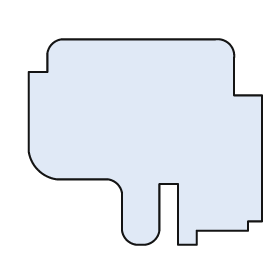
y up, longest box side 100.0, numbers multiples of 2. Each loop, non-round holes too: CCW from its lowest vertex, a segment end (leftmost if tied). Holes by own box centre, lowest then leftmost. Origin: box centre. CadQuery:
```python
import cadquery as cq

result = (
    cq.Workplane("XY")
    .moveTo(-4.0, -44.0)
    .lineTo(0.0, -44.0)
    .threePointArc((4.0, -42.0), (6.0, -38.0))
    .lineTo(6.0, -18.0)
    .lineTo(14.0, -18.0)
    .lineTo(14.0, -44.0)
    .lineTo(22.0, -44.0)
    .lineTo(22.0, -38.0)
    .lineTo(44.0, -38.0)
    .lineTo(44.0, -34.0)
    .lineTo(50.0, -34.0)
    .lineTo(50.0, 20.0)
    .lineTo(38.0, 20.0)
    .lineTo(38.0, 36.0)
    .threePointArc((36.0, 42.0), (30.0, 44.0))
    .lineTo(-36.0, 44.0)
    .threePointArc((-40.0, 42.0), (-42.0, 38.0))
    .lineTo(-42.0, 30.0)
    .lineTo(-50.0, 30.0)
    .lineTo(-50.0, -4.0)
    .threePointArc((-46.0, -12.0), (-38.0, -16.0))
    .lineTo(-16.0, -16.0)
    .threePointArc((-12.0, -18.0), (-10.0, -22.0))
    .lineTo(-10.0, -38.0)
    .threePointArc((-8.0, -42.0), (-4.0, -44.0))
    .close()
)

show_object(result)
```